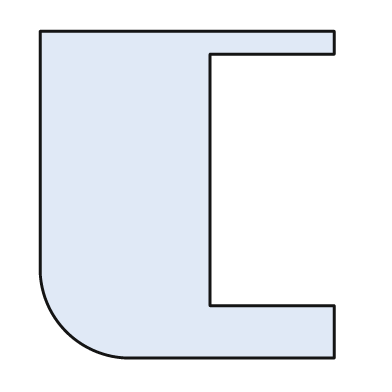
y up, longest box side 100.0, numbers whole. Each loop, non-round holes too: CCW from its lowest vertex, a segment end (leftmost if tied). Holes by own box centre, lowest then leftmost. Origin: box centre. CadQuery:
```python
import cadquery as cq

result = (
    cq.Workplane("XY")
    .moveTo(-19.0, -50.0)
    .lineTo(45.0, -50.0)
    .lineTo(45.0, -34.0)
    .lineTo(7.0, -34.0)
    .lineTo(7.0, 43.0)
    .lineTo(45.0, 43.0)
    .lineTo(45.0, 50.0)
    .lineTo(-45.0, 50.0)
    .lineTo(-45.0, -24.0)
    .threePointArc((-37.0, -42.0), (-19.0, -50.0))
    .close()
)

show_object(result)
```